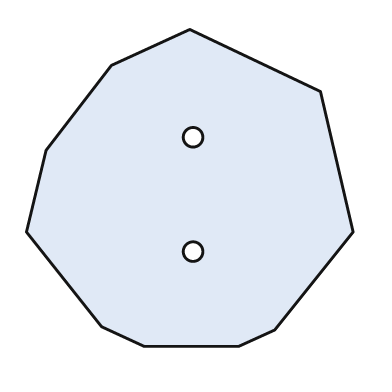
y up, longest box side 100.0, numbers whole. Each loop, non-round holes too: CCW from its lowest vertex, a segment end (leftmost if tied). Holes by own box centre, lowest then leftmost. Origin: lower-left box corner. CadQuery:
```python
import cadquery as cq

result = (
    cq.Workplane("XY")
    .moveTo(36.0, 0.0)
    .lineTo(65.0, 0.0)
    .lineTo(76.0, 5.0)
    .lineTo(100.0, 35.0)
    .lineTo(90.0, 78.0)
    .lineTo(50.0, 97.0)
    .lineTo(26.0, 86.0)
    .lineTo(6.0, 60.0)
    .lineTo(0.0, 35.0)
    .lineTo(23.0, 6.0)
    .close()
    .moveTo(51.0, 29.0)
    .circle(3.0)
    .moveTo(51.0, 64.0)
    .circle(3.0)
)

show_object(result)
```